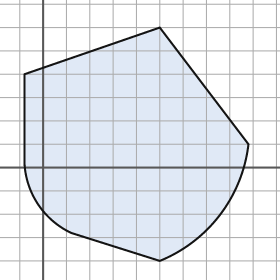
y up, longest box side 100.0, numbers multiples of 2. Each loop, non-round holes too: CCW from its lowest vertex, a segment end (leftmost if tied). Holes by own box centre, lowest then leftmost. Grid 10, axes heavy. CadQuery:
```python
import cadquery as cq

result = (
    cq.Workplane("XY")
    .moveTo(50.0, -40.0)
    .threePointArc((76.0, -20.0), (88.0, 10.0))
    .lineTo(50.0, 60.0)
    .lineTo(-8.0, 40.0)
    .lineTo(-8.0, 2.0)
    .threePointArc((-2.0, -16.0), (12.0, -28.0))
    .close()
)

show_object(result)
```